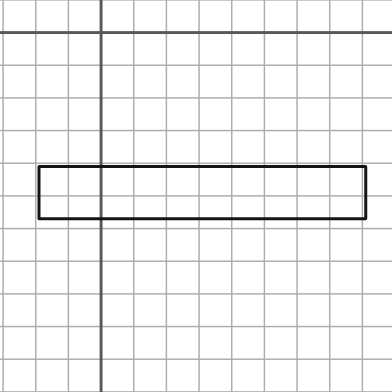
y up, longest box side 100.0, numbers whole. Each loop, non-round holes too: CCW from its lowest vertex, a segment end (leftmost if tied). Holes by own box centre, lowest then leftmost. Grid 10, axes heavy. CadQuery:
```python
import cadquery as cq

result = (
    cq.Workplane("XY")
    .moveTo(-19.0, -57.0)
    .lineTo(81.0, -57.0)
    .lineTo(81.0, -41.0)
    .lineTo(-19.0, -41.0)
    .close()
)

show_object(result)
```